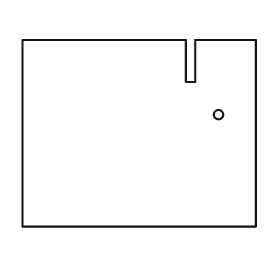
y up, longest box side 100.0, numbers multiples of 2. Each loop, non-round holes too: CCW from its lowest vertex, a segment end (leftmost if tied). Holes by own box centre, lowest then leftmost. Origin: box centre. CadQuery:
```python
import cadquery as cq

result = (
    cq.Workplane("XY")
    .moveTo(-50.0, -40.0)
    .lineTo(50.0, -40.0)
    .lineTo(50.0, 40.0)
    .lineTo(24.0, 40.0)
    .lineTo(24.0, 22.0)
    .lineTo(20.0, 22.0)
    .lineTo(20.0, 40.0)
    .lineTo(-50.0, 40.0)
    .close()
    .moveTo(34.0, 8.0)
    .circle(2.0)
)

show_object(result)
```